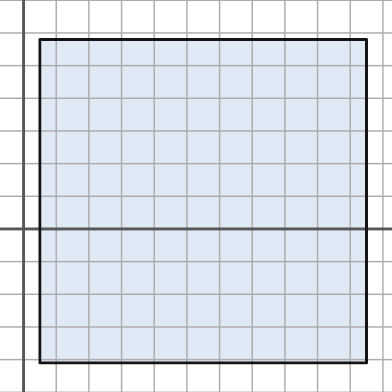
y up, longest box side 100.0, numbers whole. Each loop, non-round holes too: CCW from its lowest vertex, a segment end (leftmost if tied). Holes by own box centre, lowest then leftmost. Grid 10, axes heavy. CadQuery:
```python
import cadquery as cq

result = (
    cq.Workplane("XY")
    .moveTo(5.0, -41.0)
    .lineTo(105.0, -41.0)
    .lineTo(105.0, 58.0)
    .lineTo(5.0, 58.0)
    .close()
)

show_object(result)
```